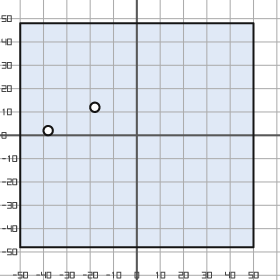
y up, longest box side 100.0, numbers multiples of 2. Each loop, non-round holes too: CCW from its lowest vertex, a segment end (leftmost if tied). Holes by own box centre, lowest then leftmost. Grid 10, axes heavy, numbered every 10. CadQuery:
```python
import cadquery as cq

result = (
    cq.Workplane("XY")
    .moveTo(-50.0, -48.0)
    .lineTo(50.0, -48.0)
    .lineTo(50.0, 48.0)
    .lineTo(-50.0, 48.0)
    .close()
    .moveTo(-38.0, 2.0)
    .circle(2.0)
    .moveTo(-18.0, 12.0)
    .circle(2.0)
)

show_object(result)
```